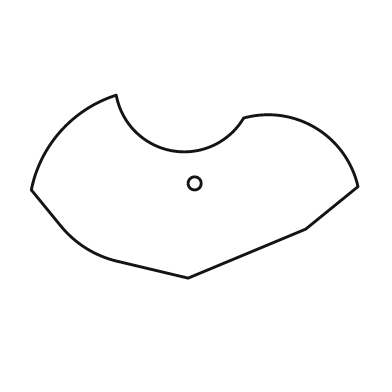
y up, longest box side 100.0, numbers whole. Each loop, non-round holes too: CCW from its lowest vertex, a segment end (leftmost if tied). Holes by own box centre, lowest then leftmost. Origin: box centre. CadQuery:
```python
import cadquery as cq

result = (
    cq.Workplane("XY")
    .moveTo(-2.0, -28.0)
    .lineTo(34.0, -13.0)
    .lineTo(50.0, 0.0)
    .threePointArc((37.0, 18.0), (15.0, 21.0))
    .threePointArc((-7.0, 11.0), (-24.0, 28.0))
    .threePointArc((-41.0, 17.0), (-50.0, -1.0))
    .lineTo(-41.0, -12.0)
    .threePointArc((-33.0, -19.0), (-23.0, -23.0))
    .close()
    .moveTo(0.0, 1.0)
    .circle(2.0)
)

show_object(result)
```